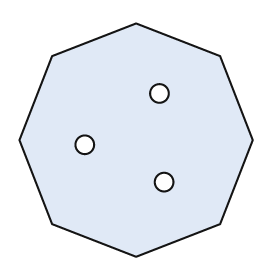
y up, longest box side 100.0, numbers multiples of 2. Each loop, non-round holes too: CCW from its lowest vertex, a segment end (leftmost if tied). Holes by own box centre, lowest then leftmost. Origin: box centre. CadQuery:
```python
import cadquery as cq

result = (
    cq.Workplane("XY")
    .moveTo(0.0, -50.0)
    .lineTo(36.0, -36.0)
    .lineTo(50.0, 0.0)
    .lineTo(36.0, 36.0)
    .lineTo(0.0, 50.0)
    .lineTo(-36.0, 36.0)
    .lineTo(-50.0, 0.0)
    .lineTo(-36.0, -36.0)
    .close()
    .moveTo(12.0, -18.0)
    .circle(4.0)
    .moveTo(-22.0, -2.0)
    .circle(4.0)
    .moveTo(10.0, 20.0)
    .circle(4.0)
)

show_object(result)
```